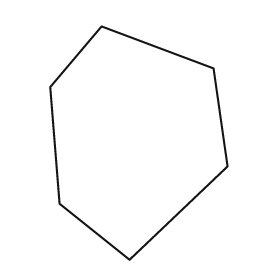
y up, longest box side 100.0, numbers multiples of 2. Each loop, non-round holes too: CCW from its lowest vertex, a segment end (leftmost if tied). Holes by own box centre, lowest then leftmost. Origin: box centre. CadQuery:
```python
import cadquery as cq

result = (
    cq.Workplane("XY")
    .moveTo(-4.0, -50.0)
    .lineTo(38.0, -10.0)
    .lineTo(32.0, 32.0)
    .lineTo(-16.0, 50.0)
    .lineTo(-38.0, 24.0)
    .lineTo(-34.0, -26.0)
    .close()
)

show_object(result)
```